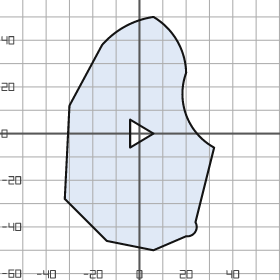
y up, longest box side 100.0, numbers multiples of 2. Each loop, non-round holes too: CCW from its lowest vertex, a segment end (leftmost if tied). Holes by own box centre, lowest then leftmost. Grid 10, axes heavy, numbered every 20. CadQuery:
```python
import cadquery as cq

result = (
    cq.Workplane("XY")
    .moveTo(6.0, -50.0)
    .lineTo(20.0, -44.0)
    .threePointArc((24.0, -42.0), (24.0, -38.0))
    .lineTo(32.0, -6.0)
    .threePointArc((20.0, 8.0), (20.0, 26.0))
    .threePointArc((16.0, 40.0), (6.0, 50.0))
    .threePointArc((-6.0, 46.0), (-16.0, 38.0))
    .lineTo(-30.0, 12.0)
    .lineTo(-32.0, -28.0)
    .lineTo(-14.0, -46.0)
    .close()
    .moveTo(-4.0, -6.0)
    .lineTo(6.0, 0.0)
    .lineTo(-4.0, 6.0)
    .close()
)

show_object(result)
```